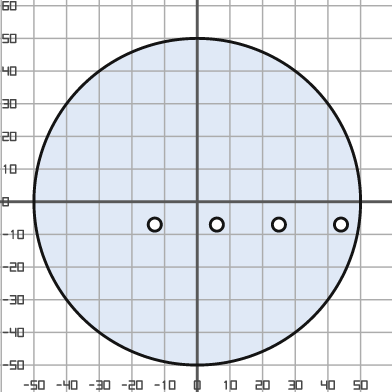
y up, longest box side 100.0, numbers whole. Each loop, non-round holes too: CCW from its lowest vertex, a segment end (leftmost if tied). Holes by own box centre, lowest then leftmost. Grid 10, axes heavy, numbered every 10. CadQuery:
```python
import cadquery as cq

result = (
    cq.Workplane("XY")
    .moveTo(0.0, 0.0)
    .circle(50.0)
    .moveTo(-13.0, -7.0)
    .circle(2.0)
    .moveTo(6.0, -7.0)
    .circle(2.0)
    .moveTo(25.0, -7.0)
    .circle(2.0)
    .moveTo(44.0, -7.0)
    .circle(2.0)
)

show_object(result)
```